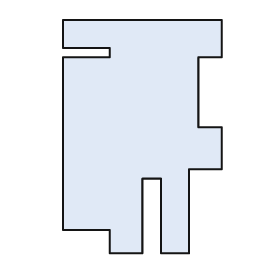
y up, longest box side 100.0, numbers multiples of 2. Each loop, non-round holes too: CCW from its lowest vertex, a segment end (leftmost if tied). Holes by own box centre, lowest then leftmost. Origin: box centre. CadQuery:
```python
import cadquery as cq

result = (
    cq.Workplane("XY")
    .moveTo(-14.0, -50.0)
    .lineTo(0.0, -50.0)
    .lineTo(0.0, -18.0)
    .lineTo(8.0, -18.0)
    .lineTo(8.0, -50.0)
    .lineTo(20.0, -50.0)
    .lineTo(20.0, -14.0)
    .lineTo(34.0, -14.0)
    .lineTo(34.0, 4.0)
    .lineTo(24.0, 4.0)
    .lineTo(24.0, 34.0)
    .lineTo(34.0, 34.0)
    .lineTo(34.0, 50.0)
    .lineTo(-34.0, 50.0)
    .lineTo(-34.0, 38.0)
    .lineTo(-14.0, 38.0)
    .lineTo(-14.0, 34.0)
    .lineTo(-34.0, 34.0)
    .lineTo(-34.0, -40.0)
    .lineTo(-14.0, -40.0)
    .close()
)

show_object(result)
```